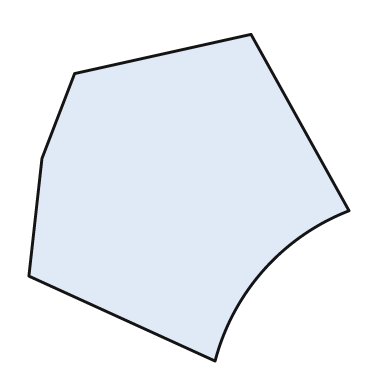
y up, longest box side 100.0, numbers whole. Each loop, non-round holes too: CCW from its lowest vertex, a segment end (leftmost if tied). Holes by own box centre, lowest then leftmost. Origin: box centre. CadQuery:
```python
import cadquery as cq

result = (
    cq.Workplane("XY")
    .moveTo(8.0, -50.0)
    .threePointArc((23.0, -22.0), (49.0, -4.0))
    .lineTo(19.0, 50.0)
    .lineTo(-35.0, 38.0)
    .lineTo(-45.0, 12.0)
    .lineTo(-49.0, -24.0)
    .close()
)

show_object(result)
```